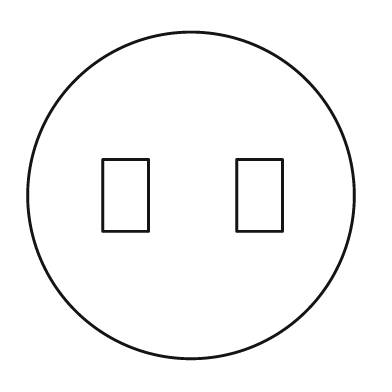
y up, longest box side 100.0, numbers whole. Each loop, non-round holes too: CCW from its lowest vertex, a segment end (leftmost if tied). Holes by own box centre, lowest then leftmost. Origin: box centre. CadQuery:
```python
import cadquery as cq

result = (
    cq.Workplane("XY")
    .moveTo(0.0, 0.0)
    .circle(50.0)
    .moveTo(-27.0, -11.0)
    .lineTo(-13.0, -11.0)
    .lineTo(-13.0, 11.0)
    .lineTo(-27.0, 11.0)
    .close()
    .moveTo(14.0, -11.0)
    .lineTo(28.0, -11.0)
    .lineTo(28.0, 11.0)
    .lineTo(14.0, 11.0)
    .close()
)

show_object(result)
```